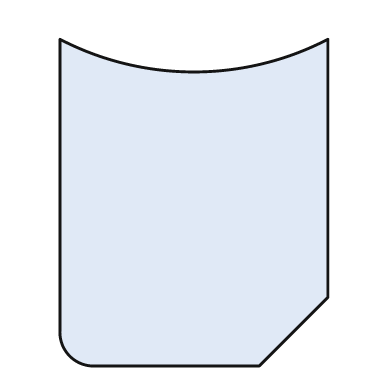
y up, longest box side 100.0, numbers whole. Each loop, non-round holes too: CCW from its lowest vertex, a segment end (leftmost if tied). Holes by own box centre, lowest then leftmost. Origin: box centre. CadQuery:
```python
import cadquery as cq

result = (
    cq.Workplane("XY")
    .moveTo(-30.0, -50.0)
    .lineTo(20.0, -50.0)
    .lineTo(41.0, -29.0)
    .lineTo(41.0, 50.0)
    .threePointArc((0.0, 40.0), (-41.0, 50.0))
    .lineTo(-41.0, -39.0)
    .threePointArc((-38.0, -47.0), (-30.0, -50.0))
    .close()
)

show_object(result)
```